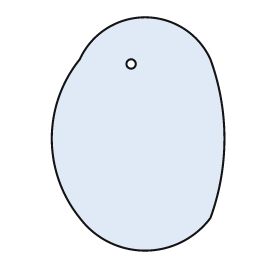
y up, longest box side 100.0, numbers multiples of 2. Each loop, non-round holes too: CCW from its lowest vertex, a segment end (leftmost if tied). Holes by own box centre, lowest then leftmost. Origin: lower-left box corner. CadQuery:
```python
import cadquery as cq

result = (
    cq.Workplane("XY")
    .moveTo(12.0, 14.0)
    .threePointArc((40.0, 0.0), (68.0, 14.0))
    .threePointArc((74.0, 48.0), (68.0, 82.0))
    .threePointArc((40.0, 100.0), (12.0, 82.0))
    .threePointArc((0.0, 48.0), (12.0, 14.0))
    .close()
    .moveTo(34.0, 80.0)
    .circle(2.0)
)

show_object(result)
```